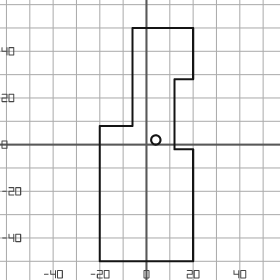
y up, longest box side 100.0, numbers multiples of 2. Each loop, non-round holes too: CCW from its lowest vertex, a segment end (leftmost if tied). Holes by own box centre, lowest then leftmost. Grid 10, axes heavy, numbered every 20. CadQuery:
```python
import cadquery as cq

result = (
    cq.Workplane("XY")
    .moveTo(-20.0, -50.0)
    .lineTo(20.0, -50.0)
    .lineTo(20.0, -2.0)
    .lineTo(12.0, -2.0)
    .lineTo(12.0, 28.0)
    .lineTo(20.0, 28.0)
    .lineTo(20.0, 50.0)
    .lineTo(-6.0, 50.0)
    .lineTo(-6.0, 8.0)
    .lineTo(-20.0, 8.0)
    .close()
    .moveTo(4.0, 2.0)
    .circle(2.0)
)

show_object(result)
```